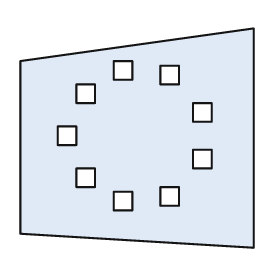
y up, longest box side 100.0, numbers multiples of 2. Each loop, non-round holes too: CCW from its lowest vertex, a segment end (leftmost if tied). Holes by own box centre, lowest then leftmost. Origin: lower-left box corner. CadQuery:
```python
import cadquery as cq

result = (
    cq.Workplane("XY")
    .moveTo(100.0, 0.0)
    .lineTo(100.0, 94.0)
    .lineTo(0.0, 80.0)
    .lineTo(0.0, 6.0)
    .close()
    .moveTo(40.0, 16.0)
    .lineTo(48.0, 16.0)
    .lineTo(48.0, 24.0)
    .lineTo(40.0, 24.0)
    .close()
    .moveTo(60.0, 18.0)
    .lineTo(68.0, 18.0)
    .lineTo(68.0, 26.0)
    .lineTo(60.0, 26.0)
    .close()
    .moveTo(24.0, 26.0)
    .lineTo(32.0, 26.0)
    .lineTo(32.0, 34.0)
    .lineTo(24.0, 34.0)
    .close()
    .moveTo(74.0, 34.0)
    .lineTo(82.0, 34.0)
    .lineTo(82.0, 42.0)
    .lineTo(74.0, 42.0)
    .close()
    .moveTo(16.0, 44.0)
    .lineTo(24.0, 44.0)
    .lineTo(24.0, 52.0)
    .lineTo(16.0, 52.0)
    .close()
    .moveTo(74.0, 54.0)
    .lineTo(82.0, 54.0)
    .lineTo(82.0, 62.0)
    .lineTo(74.0, 62.0)
    .close()
    .moveTo(24.0, 62.0)
    .lineTo(32.0, 62.0)
    .lineTo(32.0, 70.0)
    .lineTo(24.0, 70.0)
    .close()
    .moveTo(60.0, 70.0)
    .lineTo(68.0, 70.0)
    .lineTo(68.0, 78.0)
    .lineTo(60.0, 78.0)
    .close()
    .moveTo(40.0, 72.0)
    .lineTo(48.0, 72.0)
    .lineTo(48.0, 80.0)
    .lineTo(40.0, 80.0)
    .close()
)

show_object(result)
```